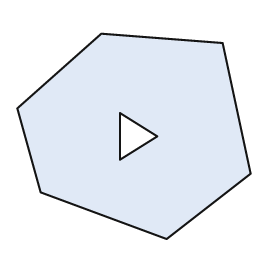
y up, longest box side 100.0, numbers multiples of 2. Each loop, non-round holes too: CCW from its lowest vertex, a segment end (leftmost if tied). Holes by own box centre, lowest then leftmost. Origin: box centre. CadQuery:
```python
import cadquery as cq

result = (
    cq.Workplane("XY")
    .moveTo(14.0, -44.0)
    .lineTo(50.0, -16.0)
    .lineTo(38.0, 40.0)
    .lineTo(-14.0, 44.0)
    .lineTo(-50.0, 12.0)
    .lineTo(-40.0, -24.0)
    .close()
    .moveTo(-6.0, -10.0)
    .lineTo(10.0, 0.0)
    .lineTo(-6.0, 10.0)
    .close()
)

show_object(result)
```